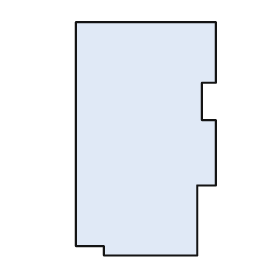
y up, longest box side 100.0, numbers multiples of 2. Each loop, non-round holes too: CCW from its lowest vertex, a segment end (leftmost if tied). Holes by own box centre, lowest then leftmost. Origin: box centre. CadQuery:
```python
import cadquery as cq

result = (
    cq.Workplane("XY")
    .moveTo(-18.0, -50.0)
    .lineTo(22.0, -50.0)
    .lineTo(22.0, -20.0)
    .lineTo(30.0, -20.0)
    .lineTo(30.0, 8.0)
    .lineTo(24.0, 8.0)
    .lineTo(24.0, 24.0)
    .lineTo(30.0, 24.0)
    .lineTo(30.0, 50.0)
    .lineTo(-30.0, 50.0)
    .lineTo(-30.0, -46.0)
    .lineTo(-18.0, -46.0)
    .close()
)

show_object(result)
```